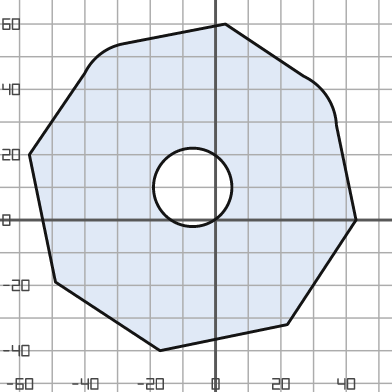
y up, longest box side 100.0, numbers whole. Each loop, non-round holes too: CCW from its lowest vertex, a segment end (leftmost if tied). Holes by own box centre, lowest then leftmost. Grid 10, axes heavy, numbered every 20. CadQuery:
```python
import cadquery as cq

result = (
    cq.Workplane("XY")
    .moveTo(-17.0, -40.0)
    .lineTo(22.0, -32.0)
    .lineTo(43.0, 0.0)
    .lineTo(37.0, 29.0)
    .threePointArc((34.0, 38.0), (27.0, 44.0))
    .lineTo(3.0, 60.0)
    .lineTo(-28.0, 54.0)
    .threePointArc((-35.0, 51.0), (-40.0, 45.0))
    .lineTo(-57.0, 20.0)
    .lineTo(-49.0, -19.0)
    .close()
    .moveTo(-7.0, 10.0)
    .circle(12.0)
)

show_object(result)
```